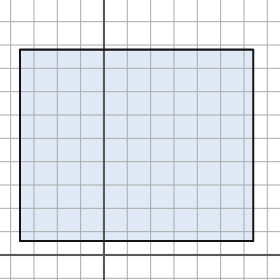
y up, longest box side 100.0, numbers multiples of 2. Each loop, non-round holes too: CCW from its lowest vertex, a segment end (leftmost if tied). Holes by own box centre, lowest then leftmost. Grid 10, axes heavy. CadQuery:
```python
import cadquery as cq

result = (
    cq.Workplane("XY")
    .moveTo(-36.0, 6.0)
    .lineTo(64.0, 6.0)
    .lineTo(64.0, 88.0)
    .lineTo(-36.0, 88.0)
    .close()
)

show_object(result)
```